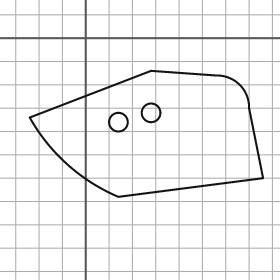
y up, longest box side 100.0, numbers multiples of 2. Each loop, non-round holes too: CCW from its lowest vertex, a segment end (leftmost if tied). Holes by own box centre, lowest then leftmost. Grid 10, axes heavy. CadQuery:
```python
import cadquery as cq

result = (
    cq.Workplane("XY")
    .moveTo(14.0, -68.0)
    .lineTo(76.0, -60.0)
    .lineTo(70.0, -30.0)
    .threePointArc((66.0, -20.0), (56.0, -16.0))
    .lineTo(28.0, -14.0)
    .lineTo(-24.0, -34.0)
    .threePointArc((-8.0, -54.0), (14.0, -68.0))
    .close()
    .moveTo(14.0, -36.0)
    .circle(4.0)
    .moveTo(28.0, -32.0)
    .circle(4.0)
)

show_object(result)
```